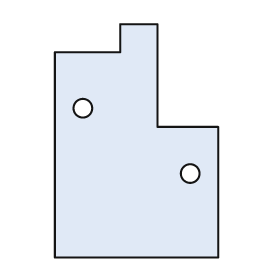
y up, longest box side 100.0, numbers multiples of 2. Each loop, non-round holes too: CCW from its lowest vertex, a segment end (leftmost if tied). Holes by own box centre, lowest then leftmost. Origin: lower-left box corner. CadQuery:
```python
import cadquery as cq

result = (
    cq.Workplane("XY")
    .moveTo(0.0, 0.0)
    .lineTo(70.0, 0.0)
    .lineTo(70.0, 56.0)
    .lineTo(44.0, 56.0)
    .lineTo(44.0, 100.0)
    .lineTo(28.0, 100.0)
    .lineTo(28.0, 88.0)
    .lineTo(0.0, 88.0)
    .close()
    .moveTo(58.0, 36.0)
    .circle(4.0)
    .moveTo(12.0, 64.0)
    .circle(4.0)
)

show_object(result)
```